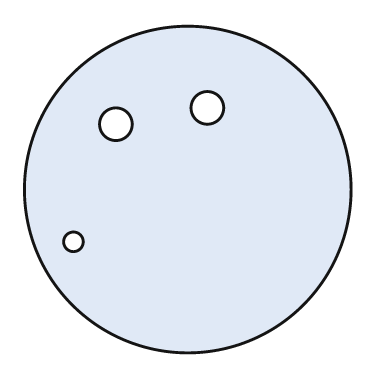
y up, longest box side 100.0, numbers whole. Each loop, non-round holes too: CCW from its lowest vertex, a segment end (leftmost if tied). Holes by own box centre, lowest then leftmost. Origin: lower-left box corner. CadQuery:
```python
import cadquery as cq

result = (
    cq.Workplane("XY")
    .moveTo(50.0, 50.0)
    .circle(50.0)
    .moveTo(15.0, 34.0)
    .circle(3.0)
    .moveTo(28.0, 70.0)
    .circle(5.0)
    .moveTo(56.0, 75.0)
    .circle(5.0)
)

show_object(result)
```